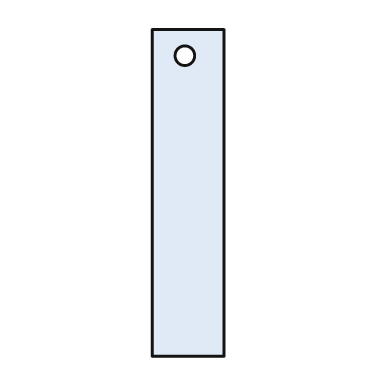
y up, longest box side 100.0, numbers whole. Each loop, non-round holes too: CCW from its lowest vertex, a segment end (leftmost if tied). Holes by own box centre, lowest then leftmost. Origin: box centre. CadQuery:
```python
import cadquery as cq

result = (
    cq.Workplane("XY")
    .moveTo(-11.0, -50.0)
    .lineTo(11.0, -50.0)
    .lineTo(11.0, 50.0)
    .lineTo(-11.0, 50.0)
    .close()
    .moveTo(-1.0, 42.0)
    .circle(3.0)
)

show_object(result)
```